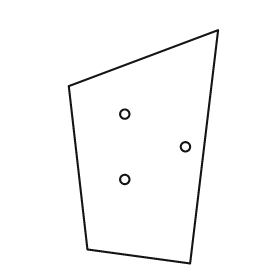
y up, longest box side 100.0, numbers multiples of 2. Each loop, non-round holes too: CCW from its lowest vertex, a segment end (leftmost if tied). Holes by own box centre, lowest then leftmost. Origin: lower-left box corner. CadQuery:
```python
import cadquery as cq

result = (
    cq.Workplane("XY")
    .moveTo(52.0, 0.0)
    .lineTo(64.0, 100.0)
    .lineTo(0.0, 76.0)
    .lineTo(8.0, 6.0)
    .close()
    .moveTo(24.0, 36.0)
    .circle(2.0)
    .moveTo(50.0, 50.0)
    .circle(2.0)
    .moveTo(24.0, 64.0)
    .circle(2.0)
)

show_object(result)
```